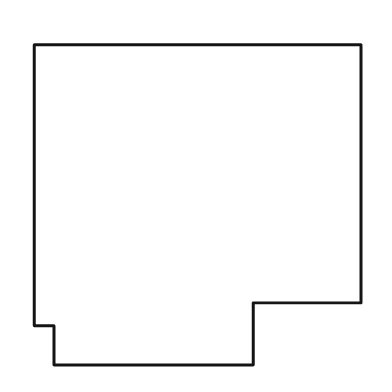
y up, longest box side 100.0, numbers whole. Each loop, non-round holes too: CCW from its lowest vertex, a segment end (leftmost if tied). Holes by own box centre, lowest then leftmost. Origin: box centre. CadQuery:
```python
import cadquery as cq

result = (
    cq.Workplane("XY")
    .moveTo(-44.0, -49.0)
    .lineTo(17.0, -49.0)
    .lineTo(17.0, -30.0)
    .lineTo(50.0, -30.0)
    .lineTo(50.0, 49.0)
    .lineTo(-50.0, 49.0)
    .lineTo(-50.0, -37.0)
    .lineTo(-44.0, -37.0)
    .close()
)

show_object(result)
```